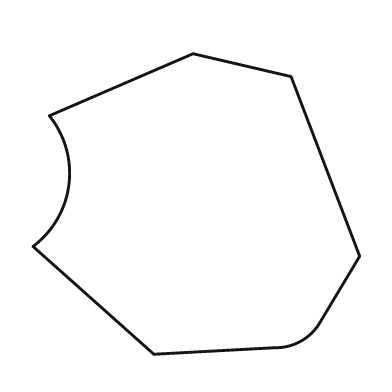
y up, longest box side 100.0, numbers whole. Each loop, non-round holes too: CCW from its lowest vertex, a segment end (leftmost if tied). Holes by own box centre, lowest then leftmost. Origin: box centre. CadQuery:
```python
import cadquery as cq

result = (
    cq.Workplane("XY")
    .moveTo(-13.0, -46.0)
    .lineTo(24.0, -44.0)
    .threePointArc((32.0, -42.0), (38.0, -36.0))
    .lineTo(50.0, -16.0)
    .lineTo(29.0, 39.0)
    .lineTo(-1.0, 46.0)
    .lineTo(-45.0, 27.0)
    .threePointArc((-39.0, 6.0), (-50.0, -13.0))
    .close()
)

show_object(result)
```